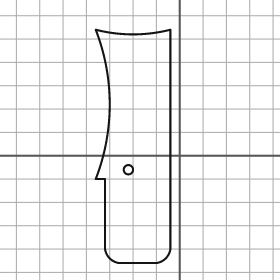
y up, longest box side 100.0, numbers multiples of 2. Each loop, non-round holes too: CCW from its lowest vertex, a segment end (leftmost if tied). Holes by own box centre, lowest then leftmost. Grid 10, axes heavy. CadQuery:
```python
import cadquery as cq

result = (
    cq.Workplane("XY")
    .moveTo(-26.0, -46.0)
    .lineTo(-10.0, -46.0)
    .threePointArc((-6.0, -44.0), (-4.0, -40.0))
    .lineTo(-4.0, 54.0)
    .threePointArc((-20.0, 52.0), (-36.0, 54.0))
    .threePointArc((-30.0, 22.0), (-36.0, -10.0))
    .lineTo(-32.0, -10.0)
    .lineTo(-32.0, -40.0)
    .threePointArc((-30.0, -44.0), (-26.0, -46.0))
    .close()
    .moveTo(-22.0, -6.0)
    .circle(2.0)
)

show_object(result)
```